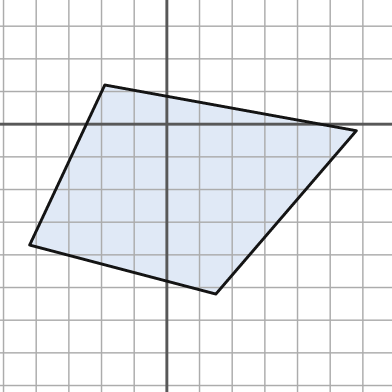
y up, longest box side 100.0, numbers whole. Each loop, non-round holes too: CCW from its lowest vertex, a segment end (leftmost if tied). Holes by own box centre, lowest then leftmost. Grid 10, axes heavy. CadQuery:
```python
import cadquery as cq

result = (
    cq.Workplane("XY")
    .moveTo(15.0, -52.0)
    .lineTo(58.0, -2.0)
    .lineTo(-19.0, 12.0)
    .lineTo(-42.0, -37.0)
    .close()
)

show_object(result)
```